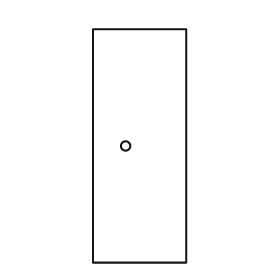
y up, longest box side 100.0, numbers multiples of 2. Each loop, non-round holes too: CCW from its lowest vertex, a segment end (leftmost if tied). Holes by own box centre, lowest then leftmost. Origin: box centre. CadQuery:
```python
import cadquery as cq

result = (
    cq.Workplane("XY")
    .moveTo(-20.0, -50.0)
    .lineTo(20.0, -50.0)
    .lineTo(20.0, 50.0)
    .lineTo(-20.0, 50.0)
    .close()
    .moveTo(-6.0, 0.0)
    .circle(2.0)
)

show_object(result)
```